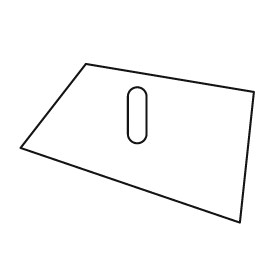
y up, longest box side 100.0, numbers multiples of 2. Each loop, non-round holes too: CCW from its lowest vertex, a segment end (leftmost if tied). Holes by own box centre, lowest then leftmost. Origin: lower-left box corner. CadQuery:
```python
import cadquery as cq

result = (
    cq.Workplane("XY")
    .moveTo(94.0, 0.0)
    .lineTo(100.0, 56.0)
    .lineTo(28.0, 68.0)
    .lineTo(0.0, 32.0)
    .close()
    .moveTo(46.0, 38.0)
    .threePointArc((50.0, 34.0), (54.0, 38.0))
    .lineTo(54.0, 54.0)
    .threePointArc((50.0, 58.0), (46.0, 54.0))
    .close()
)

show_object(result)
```